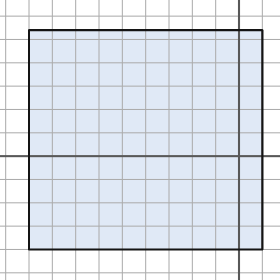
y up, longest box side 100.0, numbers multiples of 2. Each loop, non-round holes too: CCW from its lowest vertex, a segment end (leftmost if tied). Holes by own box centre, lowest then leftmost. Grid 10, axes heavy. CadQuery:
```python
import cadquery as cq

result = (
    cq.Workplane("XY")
    .moveTo(-90.0, -40.0)
    .lineTo(10.0, -40.0)
    .lineTo(10.0, 54.0)
    .lineTo(-90.0, 54.0)
    .close()
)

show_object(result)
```